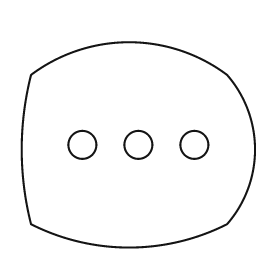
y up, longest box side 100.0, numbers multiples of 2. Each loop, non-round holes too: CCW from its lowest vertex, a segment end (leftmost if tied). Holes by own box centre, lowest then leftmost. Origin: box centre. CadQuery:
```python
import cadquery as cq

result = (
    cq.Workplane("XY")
    .moveTo(-46.0, -34.0)
    .threePointArc((-4.0, -44.0), (38.0, -34.0))
    .threePointArc((50.0, -2.0), (38.0, 30.0))
    .threePointArc((-4.0, 44.0), (-46.0, 30.0))
    .threePointArc((-50.0, -2.0), (-46.0, -34.0))
    .close()
    .moveTo(-24.0, 0.0)
    .circle(6.0)
    .moveTo(0.0, 0.0)
    .circle(6.0)
    .moveTo(24.0, 0.0)
    .circle(6.0)
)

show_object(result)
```